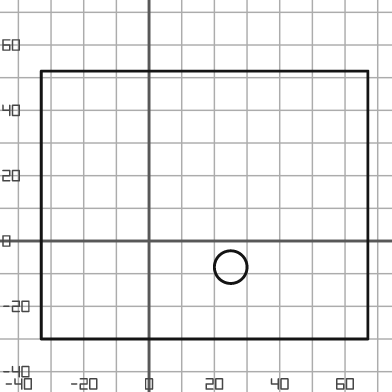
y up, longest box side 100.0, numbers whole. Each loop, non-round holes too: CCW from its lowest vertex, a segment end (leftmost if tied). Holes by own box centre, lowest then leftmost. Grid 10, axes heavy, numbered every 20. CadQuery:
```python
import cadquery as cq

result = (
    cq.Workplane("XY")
    .moveTo(-33.0, -30.0)
    .lineTo(67.0, -30.0)
    .lineTo(67.0, 52.0)
    .lineTo(-33.0, 52.0)
    .close()
    .moveTo(25.0, -8.0)
    .circle(5.0)
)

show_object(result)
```